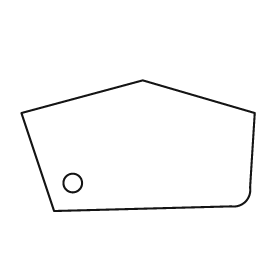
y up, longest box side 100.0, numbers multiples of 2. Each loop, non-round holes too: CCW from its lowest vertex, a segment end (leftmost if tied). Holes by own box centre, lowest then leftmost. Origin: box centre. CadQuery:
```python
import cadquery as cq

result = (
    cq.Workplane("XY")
    .moveTo(-36.0, -28.0)
    .lineTo(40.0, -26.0)
    .threePointArc((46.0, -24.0), (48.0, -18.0))
    .lineTo(50.0, 14.0)
    .lineTo(2.0, 28.0)
    .lineTo(-50.0, 14.0)
    .close()
    .moveTo(-28.0, -16.0)
    .circle(4.0)
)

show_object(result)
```